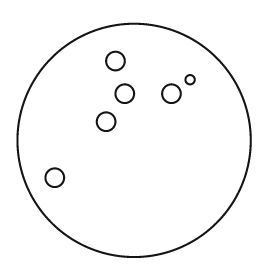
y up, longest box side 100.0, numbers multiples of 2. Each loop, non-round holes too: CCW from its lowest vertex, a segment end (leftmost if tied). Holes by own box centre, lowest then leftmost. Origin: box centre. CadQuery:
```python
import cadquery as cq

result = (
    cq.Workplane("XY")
    .moveTo(0.0, 0.0)
    .circle(50.0)
    .moveTo(-34.0, -16.0)
    .circle(4.0)
    .moveTo(-12.0, 8.0)
    .circle(4.0)
    .moveTo(-4.0, 20.0)
    .circle(4.0)
    .moveTo(16.0, 20.0)
    .circle(4.0)
    .moveTo(24.0, 26.0)
    .circle(2.0)
    .moveTo(-8.0, 34.0)
    .circle(4.0)
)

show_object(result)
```